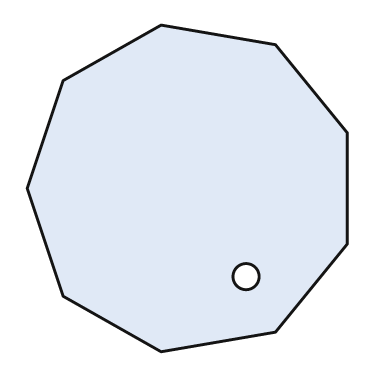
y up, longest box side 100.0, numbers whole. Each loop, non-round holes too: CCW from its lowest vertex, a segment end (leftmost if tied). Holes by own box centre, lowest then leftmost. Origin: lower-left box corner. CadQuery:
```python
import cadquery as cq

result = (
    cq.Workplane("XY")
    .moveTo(41.0, 0.0)
    .lineTo(76.0, 6.0)
    .lineTo(98.0, 33.0)
    .lineTo(98.0, 67.0)
    .lineTo(76.0, 94.0)
    .lineTo(41.0, 100.0)
    .lineTo(11.0, 83.0)
    .lineTo(0.0, 50.0)
    .lineTo(11.0, 17.0)
    .close()
    .moveTo(67.0, 23.0)
    .circle(4.0)
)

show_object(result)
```